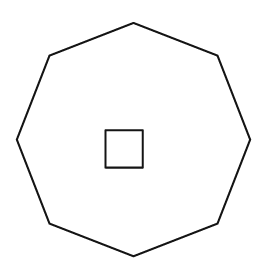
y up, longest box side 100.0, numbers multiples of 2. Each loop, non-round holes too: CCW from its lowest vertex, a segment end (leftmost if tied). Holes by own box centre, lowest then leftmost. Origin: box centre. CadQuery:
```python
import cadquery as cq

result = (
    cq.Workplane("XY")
    .moveTo(0.0, -50.0)
    .lineTo(36.0, -36.0)
    .lineTo(50.0, 0.0)
    .lineTo(36.0, 36.0)
    .lineTo(0.0, 50.0)
    .lineTo(-36.0, 36.0)
    .lineTo(-50.0, 0.0)
    .lineTo(-36.0, -36.0)
    .close()
    .moveTo(-12.0, -12.0)
    .lineTo(4.0, -12.0)
    .lineTo(4.0, 4.0)
    .lineTo(-12.0, 4.0)
    .close()
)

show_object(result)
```